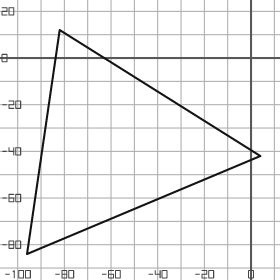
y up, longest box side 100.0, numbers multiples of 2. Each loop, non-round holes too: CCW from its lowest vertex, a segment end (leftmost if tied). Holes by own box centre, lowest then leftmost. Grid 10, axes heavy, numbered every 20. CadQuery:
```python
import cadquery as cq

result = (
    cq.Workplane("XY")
    .moveTo(-96.0, -84.0)
    .lineTo(4.0, -42.0)
    .lineTo(-82.0, 12.0)
    .close()
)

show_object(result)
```